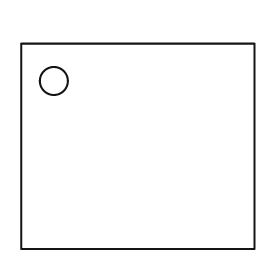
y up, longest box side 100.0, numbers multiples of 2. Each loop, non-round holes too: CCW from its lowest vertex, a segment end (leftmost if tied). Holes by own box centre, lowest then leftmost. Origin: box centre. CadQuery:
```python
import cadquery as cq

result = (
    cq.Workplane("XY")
    .moveTo(-50.0, -44.0)
    .lineTo(50.0, -44.0)
    .lineTo(50.0, 44.0)
    .lineTo(-50.0, 44.0)
    .close()
    .moveTo(-36.0, 28.0)
    .circle(6.0)
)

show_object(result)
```